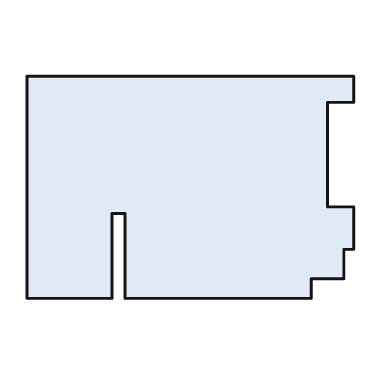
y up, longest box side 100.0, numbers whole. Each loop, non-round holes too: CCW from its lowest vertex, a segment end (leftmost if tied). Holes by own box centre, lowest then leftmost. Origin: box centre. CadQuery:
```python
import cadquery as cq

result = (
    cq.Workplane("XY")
    .moveTo(-50.0, -34.0)
    .lineTo(-24.0, -34.0)
    .lineTo(-24.0, -8.0)
    .lineTo(-20.0, -8.0)
    .lineTo(-20.0, -34.0)
    .lineTo(37.0, -34.0)
    .lineTo(37.0, -28.0)
    .lineTo(47.0, -28.0)
    .lineTo(47.0, -19.0)
    .lineTo(50.0, -19.0)
    .lineTo(50.0, -6.0)
    .lineTo(42.0, -6.0)
    .lineTo(42.0, 26.0)
    .lineTo(50.0, 26.0)
    .lineTo(50.0, 34.0)
    .lineTo(-50.0, 34.0)
    .close()
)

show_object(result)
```